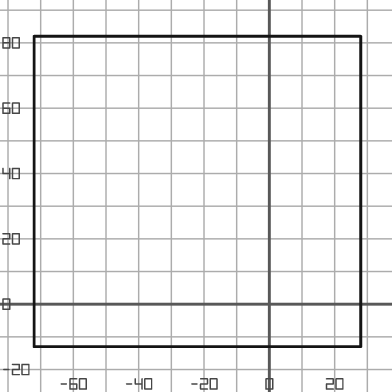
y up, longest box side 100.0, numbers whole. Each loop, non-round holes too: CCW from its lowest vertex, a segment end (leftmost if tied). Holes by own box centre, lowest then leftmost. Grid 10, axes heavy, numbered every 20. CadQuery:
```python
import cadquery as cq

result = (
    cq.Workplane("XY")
    .moveTo(-72.0, -13.0)
    .lineTo(28.0, -13.0)
    .lineTo(28.0, 82.0)
    .lineTo(-72.0, 82.0)
    .close()
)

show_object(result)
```